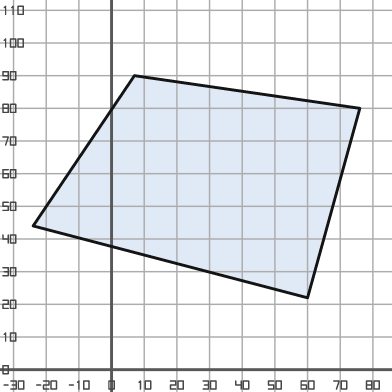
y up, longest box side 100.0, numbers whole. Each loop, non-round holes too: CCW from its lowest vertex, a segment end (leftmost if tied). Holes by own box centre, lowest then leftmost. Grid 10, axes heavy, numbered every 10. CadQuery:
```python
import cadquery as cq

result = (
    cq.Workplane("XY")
    .moveTo(60.0, 22.0)
    .lineTo(76.0, 80.0)
    .lineTo(7.0, 90.0)
    .lineTo(-24.0, 44.0)
    .close()
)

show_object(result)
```